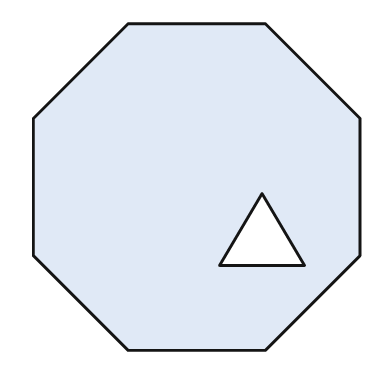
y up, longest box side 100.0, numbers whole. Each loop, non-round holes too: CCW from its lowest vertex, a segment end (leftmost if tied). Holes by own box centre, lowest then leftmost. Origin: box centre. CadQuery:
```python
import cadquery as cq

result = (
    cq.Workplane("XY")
    .moveTo(-21.0, -50.0)
    .lineTo(21.0, -50.0)
    .lineTo(50.0, -21.0)
    .lineTo(50.0, 21.0)
    .lineTo(21.0, 50.0)
    .lineTo(-21.0, 50.0)
    .lineTo(-50.0, 21.0)
    .lineTo(-50.0, -21.0)
    .close()
    .moveTo(7.0, -24.0)
    .lineTo(33.0, -24.0)
    .lineTo(20.0, -2.0)
    .close()
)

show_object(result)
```